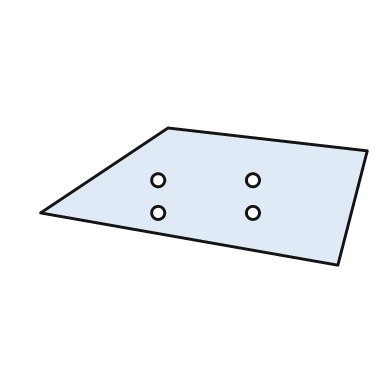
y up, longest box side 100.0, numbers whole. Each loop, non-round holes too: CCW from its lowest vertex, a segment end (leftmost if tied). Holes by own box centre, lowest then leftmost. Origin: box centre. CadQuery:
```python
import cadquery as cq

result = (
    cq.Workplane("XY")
    .moveTo(41.0, -21.0)
    .lineTo(50.0, 14.0)
    .lineTo(-11.0, 21.0)
    .lineTo(-50.0, -5.0)
    .close()
    .moveTo(-14.0, -5.0)
    .circle(2.0)
    .moveTo(15.0, -5.0)
    .circle(2.0)
    .moveTo(-14.0, 5.0)
    .circle(2.0)
    .moveTo(15.0, 5.0)
    .circle(2.0)
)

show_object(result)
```